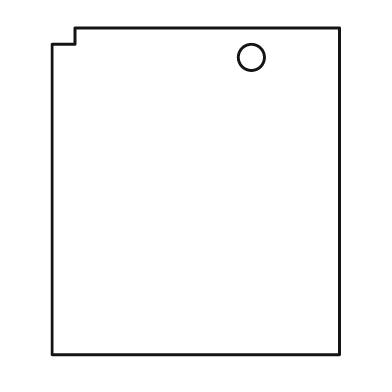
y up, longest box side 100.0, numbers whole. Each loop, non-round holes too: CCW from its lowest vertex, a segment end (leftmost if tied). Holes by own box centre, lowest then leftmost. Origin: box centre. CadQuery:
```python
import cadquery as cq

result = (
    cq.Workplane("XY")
    .moveTo(-44.0, -50.0)
    .lineTo(44.0, -50.0)
    .lineTo(44.0, 50.0)
    .lineTo(-37.0, 50.0)
    .lineTo(-37.0, 45.0)
    .lineTo(-44.0, 45.0)
    .close()
    .moveTo(17.0, 41.0)
    .circle(4.0)
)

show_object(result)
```